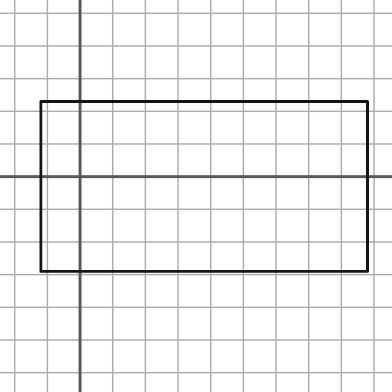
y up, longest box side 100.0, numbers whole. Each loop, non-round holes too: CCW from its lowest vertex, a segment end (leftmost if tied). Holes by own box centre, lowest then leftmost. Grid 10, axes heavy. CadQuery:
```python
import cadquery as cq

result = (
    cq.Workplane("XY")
    .moveTo(-12.0, -29.0)
    .lineTo(88.0, -29.0)
    .lineTo(88.0, 23.0)
    .lineTo(-12.0, 23.0)
    .close()
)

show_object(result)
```